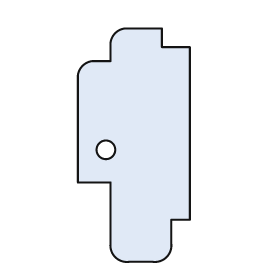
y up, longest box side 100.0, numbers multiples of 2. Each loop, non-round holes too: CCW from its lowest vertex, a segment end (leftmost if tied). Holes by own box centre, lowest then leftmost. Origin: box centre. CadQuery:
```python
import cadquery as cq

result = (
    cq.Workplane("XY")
    .moveTo(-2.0, -50.0)
    .lineTo(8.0, -50.0)
    .threePointArc((14.0, -48.0), (16.0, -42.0))
    .lineTo(16.0, -32.0)
    .lineTo(24.0, -32.0)
    .lineTo(24.0, 42.0)
    .lineTo(12.0, 42.0)
    .lineTo(12.0, 50.0)
    .lineTo(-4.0, 50.0)
    .threePointArc((-8.0, 48.0), (-10.0, 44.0))
    .lineTo(-10.0, 36.0)
    .lineTo(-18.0, 36.0)
    .threePointArc((-22.0, 34.0), (-24.0, 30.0))
    .lineTo(-24.0, -16.0)
    .lineTo(-10.0, -16.0)
    .lineTo(-10.0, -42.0)
    .threePointArc((-8.0, -48.0), (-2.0, -50.0))
    .close()
    .moveTo(-12.0, -2.0)
    .circle(4.0)
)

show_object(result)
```